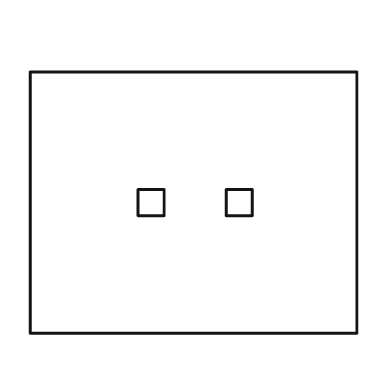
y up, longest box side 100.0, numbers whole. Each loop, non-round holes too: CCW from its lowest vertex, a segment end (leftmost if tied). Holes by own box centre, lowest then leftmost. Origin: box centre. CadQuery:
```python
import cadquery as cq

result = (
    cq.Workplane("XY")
    .moveTo(-50.0, -40.0)
    .lineTo(50.0, -40.0)
    .lineTo(50.0, 40.0)
    .lineTo(-50.0, 40.0)
    .close()
    .moveTo(-17.0, -4.0)
    .lineTo(-9.0, -4.0)
    .lineTo(-9.0, 4.0)
    .lineTo(-17.0, 4.0)
    .close()
    .moveTo(10.0, -4.0)
    .lineTo(18.0, -4.0)
    .lineTo(18.0, 4.0)
    .lineTo(10.0, 4.0)
    .close()
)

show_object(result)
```